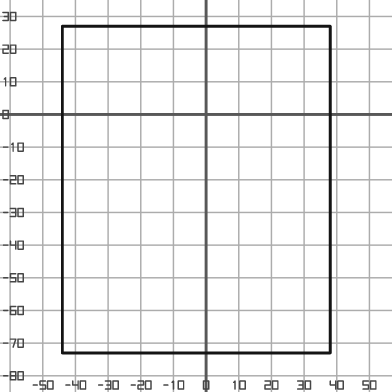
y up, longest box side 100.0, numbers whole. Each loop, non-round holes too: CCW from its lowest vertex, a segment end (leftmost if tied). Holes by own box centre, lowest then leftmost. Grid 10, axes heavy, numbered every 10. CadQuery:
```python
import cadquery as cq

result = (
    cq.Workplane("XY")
    .moveTo(-44.0, -73.0)
    .lineTo(38.0, -73.0)
    .lineTo(38.0, 27.0)
    .lineTo(-44.0, 27.0)
    .close()
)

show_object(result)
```